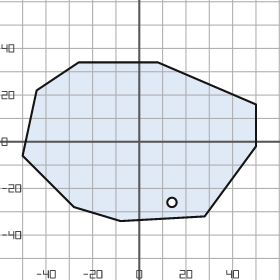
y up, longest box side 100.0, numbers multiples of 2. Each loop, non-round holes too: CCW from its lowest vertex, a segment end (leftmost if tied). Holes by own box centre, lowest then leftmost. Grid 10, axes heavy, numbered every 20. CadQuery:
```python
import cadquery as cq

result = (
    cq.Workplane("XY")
    .moveTo(-8.0, -34.0)
    .lineTo(28.0, -32.0)
    .lineTo(50.0, -2.0)
    .lineTo(50.0, 16.0)
    .lineTo(8.0, 34.0)
    .lineTo(-26.0, 34.0)
    .lineTo(-44.0, 22.0)
    .lineTo(-50.0, -6.0)
    .lineTo(-28.0, -28.0)
    .close()
    .moveTo(14.0, -26.0)
    .circle(2.0)
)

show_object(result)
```